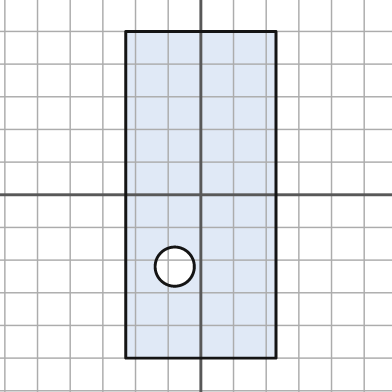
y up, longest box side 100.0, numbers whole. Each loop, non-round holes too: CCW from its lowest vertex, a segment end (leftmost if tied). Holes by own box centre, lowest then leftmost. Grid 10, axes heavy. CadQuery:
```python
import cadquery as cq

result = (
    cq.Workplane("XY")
    .moveTo(-23.0, -50.0)
    .lineTo(23.0, -50.0)
    .lineTo(23.0, 50.0)
    .lineTo(-23.0, 50.0)
    .close()
    .moveTo(-8.0, -22.0)
    .circle(6.0)
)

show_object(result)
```